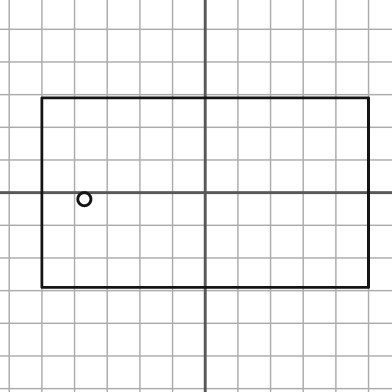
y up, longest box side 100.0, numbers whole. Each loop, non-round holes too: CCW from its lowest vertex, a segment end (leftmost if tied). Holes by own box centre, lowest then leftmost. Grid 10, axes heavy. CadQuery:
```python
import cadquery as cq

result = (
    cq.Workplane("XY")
    .moveTo(-50.0, -29.0)
    .lineTo(50.0, -29.0)
    .lineTo(50.0, 29.0)
    .lineTo(-50.0, 29.0)
    .close()
    .moveTo(-37.0, -2.0)
    .circle(2.0)
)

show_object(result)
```